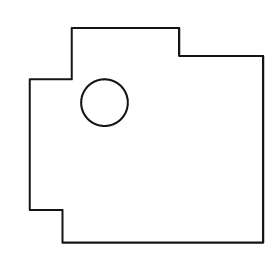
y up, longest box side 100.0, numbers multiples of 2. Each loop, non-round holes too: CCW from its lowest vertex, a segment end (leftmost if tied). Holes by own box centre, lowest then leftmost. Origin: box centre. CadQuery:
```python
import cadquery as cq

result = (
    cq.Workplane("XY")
    .moveTo(-36.0, -46.0)
    .lineTo(50.0, -46.0)
    .lineTo(50.0, 34.0)
    .lineTo(14.0, 34.0)
    .lineTo(14.0, 46.0)
    .lineTo(-32.0, 46.0)
    .lineTo(-32.0, 24.0)
    .lineTo(-50.0, 24.0)
    .lineTo(-50.0, -32.0)
    .lineTo(-36.0, -32.0)
    .close()
    .moveTo(-18.0, 14.0)
    .circle(10.0)
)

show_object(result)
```